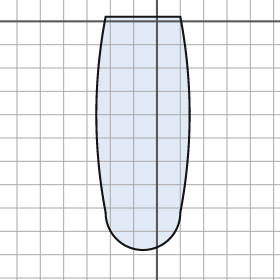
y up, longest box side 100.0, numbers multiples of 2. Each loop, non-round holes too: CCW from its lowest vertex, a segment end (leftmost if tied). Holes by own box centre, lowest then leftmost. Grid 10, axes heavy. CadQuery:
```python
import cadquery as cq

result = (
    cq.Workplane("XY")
    .moveTo(-22.0, -82.0)
    .threePointArc((-6.0, -98.0), (10.0, -82.0))
    .threePointArc((14.0, -40.0), (10.0, 2.0))
    .lineTo(-22.0, 2.0)
    .threePointArc((-26.0, -40.0), (-22.0, -82.0))
    .close()
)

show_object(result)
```